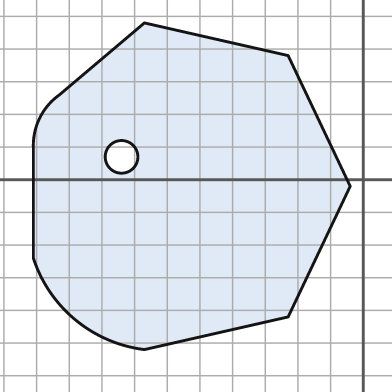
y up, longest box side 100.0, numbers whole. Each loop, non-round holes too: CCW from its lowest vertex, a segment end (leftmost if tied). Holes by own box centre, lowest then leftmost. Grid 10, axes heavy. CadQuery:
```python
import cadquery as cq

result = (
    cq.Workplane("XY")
    .moveTo(-67.0, -52.0)
    .lineTo(-23.0, -42.0)
    .lineTo(-4.0, -2.0)
    .lineTo(-23.0, 38.0)
    .lineTo(-67.0, 48.0)
    .lineTo(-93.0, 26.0)
    .threePointArc((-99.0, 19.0), (-101.0, 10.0))
    .lineTo(-101.0, -24.0)
    .threePointArc((-88.0, -43.0), (-67.0, -52.0))
    .close()
    .moveTo(-74.0, 7.0)
    .circle(5.0)
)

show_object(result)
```